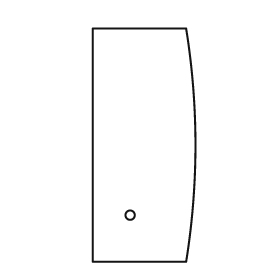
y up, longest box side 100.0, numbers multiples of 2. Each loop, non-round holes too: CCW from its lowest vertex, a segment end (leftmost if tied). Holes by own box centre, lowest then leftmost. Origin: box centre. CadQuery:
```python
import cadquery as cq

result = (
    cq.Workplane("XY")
    .moveTo(-22.0, -50.0)
    .lineTo(18.0, -50.0)
    .threePointArc((22.0, 0.0), (18.0, 50.0))
    .lineTo(-22.0, 50.0)
    .close()
    .moveTo(-6.0, -30.0)
    .circle(2.0)
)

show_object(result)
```